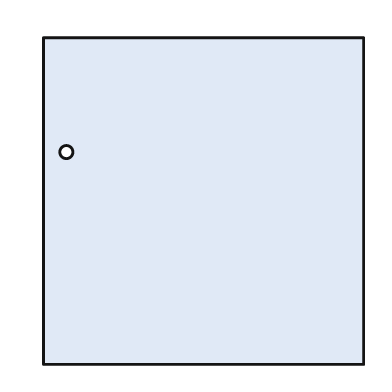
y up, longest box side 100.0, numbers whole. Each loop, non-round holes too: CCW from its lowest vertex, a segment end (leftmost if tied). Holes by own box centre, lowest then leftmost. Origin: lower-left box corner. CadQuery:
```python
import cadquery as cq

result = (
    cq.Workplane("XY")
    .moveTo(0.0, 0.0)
    .lineTo(98.0, 0.0)
    .lineTo(98.0, 100.0)
    .lineTo(0.0, 100.0)
    .close()
    .moveTo(7.0, 65.0)
    .circle(2.0)
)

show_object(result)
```